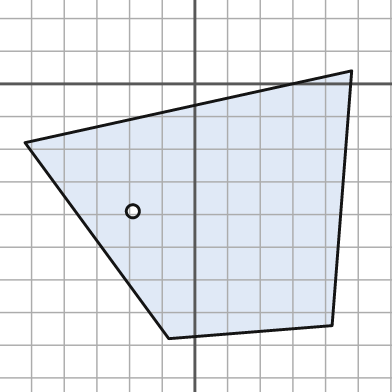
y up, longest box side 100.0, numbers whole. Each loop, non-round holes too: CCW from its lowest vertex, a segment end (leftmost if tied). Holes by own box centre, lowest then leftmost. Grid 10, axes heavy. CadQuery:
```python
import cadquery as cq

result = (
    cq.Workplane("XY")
    .moveTo(-8.0, -78.0)
    .lineTo(42.0, -74.0)
    .lineTo(48.0, 4.0)
    .lineTo(-52.0, -18.0)
    .close()
    .moveTo(-19.0, -39.0)
    .circle(2.0)
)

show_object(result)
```